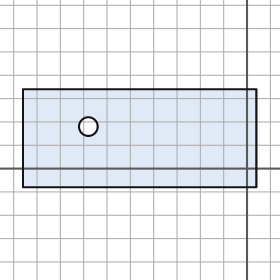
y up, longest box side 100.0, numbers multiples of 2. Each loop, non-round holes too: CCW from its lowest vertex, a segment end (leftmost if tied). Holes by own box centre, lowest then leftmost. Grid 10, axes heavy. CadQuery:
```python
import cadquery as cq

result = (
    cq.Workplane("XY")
    .moveTo(-96.0, -8.0)
    .lineTo(4.0, -8.0)
    .lineTo(4.0, 34.0)
    .lineTo(-96.0, 34.0)
    .close()
    .moveTo(-68.0, 18.0)
    .circle(4.0)
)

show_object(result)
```